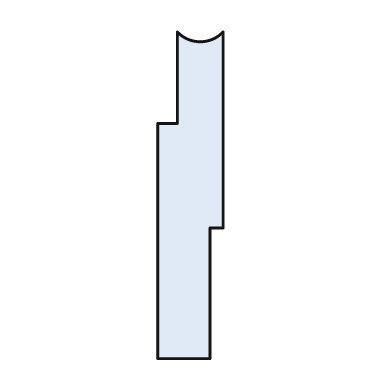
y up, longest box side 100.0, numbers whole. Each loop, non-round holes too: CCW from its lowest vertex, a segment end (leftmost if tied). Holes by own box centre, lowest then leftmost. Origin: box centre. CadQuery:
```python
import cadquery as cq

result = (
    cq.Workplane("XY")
    .moveTo(-10.0, -50.0)
    .lineTo(6.0, -50.0)
    .lineTo(6.0, -10.0)
    .lineTo(10.0, -10.0)
    .lineTo(10.0, 50.0)
    .threePointArc((3.0, 47.0), (-4.0, 50.0))
    .lineTo(-4.0, 22.0)
    .lineTo(-10.0, 22.0)
    .close()
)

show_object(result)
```